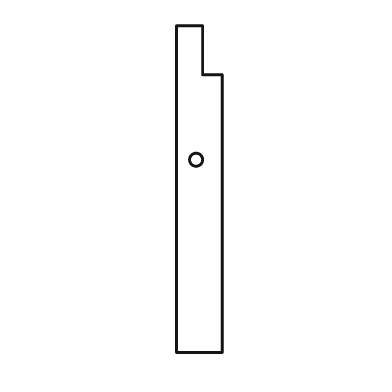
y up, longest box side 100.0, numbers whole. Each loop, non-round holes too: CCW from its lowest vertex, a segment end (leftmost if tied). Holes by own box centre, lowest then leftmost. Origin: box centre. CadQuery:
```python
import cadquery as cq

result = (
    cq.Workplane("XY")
    .moveTo(-7.0, -50.0)
    .lineTo(7.0, -50.0)
    .lineTo(7.0, 35.0)
    .lineTo(1.0, 35.0)
    .lineTo(1.0, 50.0)
    .lineTo(-7.0, 50.0)
    .close()
    .moveTo(-1.0, 9.0)
    .circle(2.0)
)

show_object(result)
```